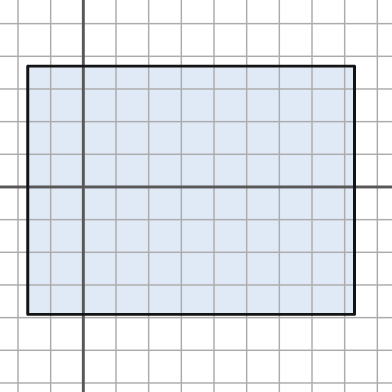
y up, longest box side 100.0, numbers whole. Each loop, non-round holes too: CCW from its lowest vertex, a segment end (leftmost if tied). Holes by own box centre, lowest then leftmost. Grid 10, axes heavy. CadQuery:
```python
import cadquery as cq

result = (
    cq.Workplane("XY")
    .moveTo(-17.0, -39.0)
    .lineTo(83.0, -39.0)
    .lineTo(83.0, 37.0)
    .lineTo(-17.0, 37.0)
    .close()
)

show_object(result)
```